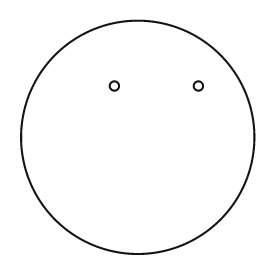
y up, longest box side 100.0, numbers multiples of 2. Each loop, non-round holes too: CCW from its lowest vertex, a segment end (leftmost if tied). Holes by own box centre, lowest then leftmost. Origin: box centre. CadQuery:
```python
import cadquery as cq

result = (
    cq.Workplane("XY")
    .moveTo(0.0, 0.0)
    .circle(50.0)
    .moveTo(-10.0, 22.0)
    .circle(2.0)
    .moveTo(26.0, 22.0)
    .circle(2.0)
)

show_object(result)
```